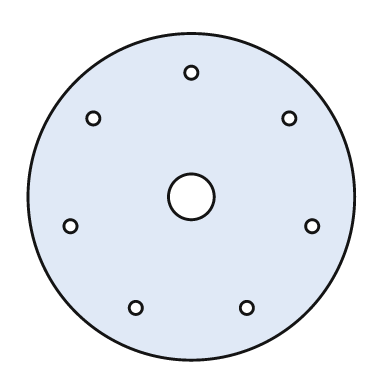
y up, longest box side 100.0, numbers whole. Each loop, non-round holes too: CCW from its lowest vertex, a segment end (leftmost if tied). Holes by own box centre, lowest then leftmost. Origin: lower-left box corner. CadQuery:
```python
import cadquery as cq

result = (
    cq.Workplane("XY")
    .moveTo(50.0, 50.0)
    .circle(50.0)
    .moveTo(33.0, 16.0)
    .circle(2.0)
    .moveTo(67.0, 16.0)
    .circle(2.0)
    .moveTo(13.0, 41.0)
    .circle(2.0)
    .moveTo(87.0, 41.0)
    .circle(2.0)
    .moveTo(50.0, 50.0)
    .circle(7.0)
    .moveTo(20.0, 74.0)
    .circle(2.0)
    .moveTo(80.0, 74.0)
    .circle(2.0)
    .moveTo(50.0, 88.0)
    .circle(2.0)
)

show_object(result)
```